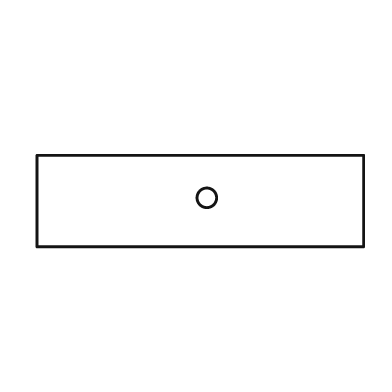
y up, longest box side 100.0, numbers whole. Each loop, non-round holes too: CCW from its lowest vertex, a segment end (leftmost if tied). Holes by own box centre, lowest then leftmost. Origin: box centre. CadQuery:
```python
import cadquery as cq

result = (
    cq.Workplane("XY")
    .moveTo(-50.0, -14.0)
    .lineTo(50.0, -14.0)
    .lineTo(50.0, 14.0)
    .lineTo(-50.0, 14.0)
    .close()
    .moveTo(2.0, 1.0)
    .circle(3.0)
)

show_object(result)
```